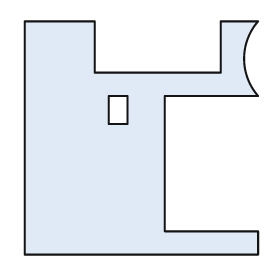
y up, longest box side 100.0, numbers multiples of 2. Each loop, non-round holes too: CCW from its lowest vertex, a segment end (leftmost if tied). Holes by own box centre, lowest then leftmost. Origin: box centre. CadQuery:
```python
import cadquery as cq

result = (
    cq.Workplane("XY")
    .moveTo(-50.0, -50.0)
    .lineTo(50.0, -50.0)
    .lineTo(50.0, -40.0)
    .lineTo(10.0, -40.0)
    .lineTo(10.0, 18.0)
    .lineTo(50.0, 18.0)
    .threePointArc((44.0, 34.0), (50.0, 50.0))
    .lineTo(34.0, 50.0)
    .lineTo(34.0, 28.0)
    .lineTo(-20.0, 28.0)
    .lineTo(-20.0, 50.0)
    .lineTo(-50.0, 50.0)
    .close()
    .moveTo(-14.0, 6.0)
    .lineTo(-6.0, 6.0)
    .lineTo(-6.0, 18.0)
    .lineTo(-14.0, 18.0)
    .close()
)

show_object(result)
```